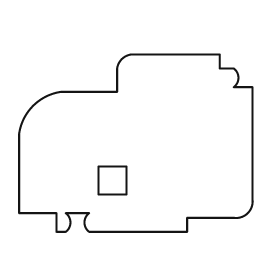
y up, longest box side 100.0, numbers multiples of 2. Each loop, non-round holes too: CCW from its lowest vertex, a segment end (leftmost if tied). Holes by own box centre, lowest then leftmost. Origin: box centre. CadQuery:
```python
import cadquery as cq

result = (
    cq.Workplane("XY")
    .moveTo(-34.0, -38.0)
    .lineTo(-30.0, -38.0)
    .threePointArc((-28.0, -34.0), (-30.0, -30.0))
    .lineTo(-20.0, -30.0)
    .threePointArc((-22.0, -34.0), (-20.0, -38.0))
    .lineTo(22.0, -38.0)
    .lineTo(22.0, -32.0)
    .lineTo(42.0, -32.0)
    .threePointArc((48.0, -30.0), (50.0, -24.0))
    .lineTo(50.0, 24.0)
    .lineTo(42.0, 24.0)
    .threePointArc((44.0, 28.0), (42.0, 32.0))
    .lineTo(36.0, 32.0)
    .lineTo(36.0, 38.0)
    .lineTo(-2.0, 38.0)
    .threePointArc((-6.0, 36.0), (-8.0, 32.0))
    .lineTo(-8.0, 22.0)
    .lineTo(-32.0, 22.0)
    .threePointArc((-44.0, 16.0), (-50.0, 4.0))
    .lineTo(-50.0, -30.0)
    .lineTo(-34.0, -30.0)
    .close()
    .moveTo(-16.0, -22.0)
    .lineTo(-4.0, -22.0)
    .lineTo(-4.0, -10.0)
    .lineTo(-16.0, -10.0)
    .close()
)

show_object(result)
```